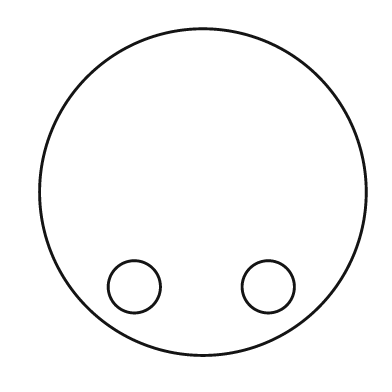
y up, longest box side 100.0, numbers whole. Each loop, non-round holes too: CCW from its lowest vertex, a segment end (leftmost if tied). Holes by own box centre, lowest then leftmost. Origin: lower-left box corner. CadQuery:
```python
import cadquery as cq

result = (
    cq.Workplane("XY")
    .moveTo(50.0, 50.0)
    .circle(50.0)
    .moveTo(29.0, 21.0)
    .circle(8.0)
    .moveTo(70.0, 21.0)
    .circle(8.0)
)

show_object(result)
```